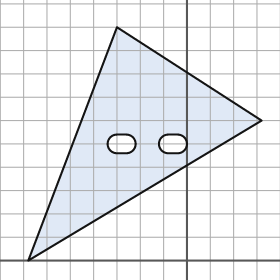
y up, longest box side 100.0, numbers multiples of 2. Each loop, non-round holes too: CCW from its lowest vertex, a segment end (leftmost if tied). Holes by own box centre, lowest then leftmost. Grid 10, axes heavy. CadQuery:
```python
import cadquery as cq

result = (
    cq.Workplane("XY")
    .moveTo(-68.0, 0.0)
    .lineTo(32.0, 60.0)
    .lineTo(-30.0, 100.0)
    .close()
    .moveTo(-30.0, 46.0)
    .lineTo(-26.0, 46.0)
    .threePointArc((-22.0, 50.0), (-26.0, 54.0))
    .lineTo(-30.0, 54.0)
    .threePointArc((-34.0, 50.0), (-30.0, 46.0))
    .close()
    .moveTo(-8.0, 46.0)
    .lineTo(-4.0, 46.0)
    .threePointArc((0.0, 50.0), (-4.0, 54.0))
    .lineTo(-8.0, 54.0)
    .threePointArc((-12.0, 50.0), (-8.0, 46.0))
    .close()
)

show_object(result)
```